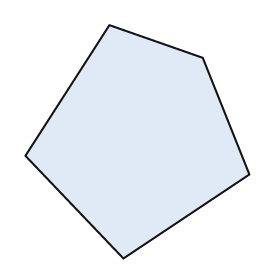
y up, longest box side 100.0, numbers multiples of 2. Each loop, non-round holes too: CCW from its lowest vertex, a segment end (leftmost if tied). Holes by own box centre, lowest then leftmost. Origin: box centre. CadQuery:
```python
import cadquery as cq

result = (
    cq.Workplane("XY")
    .moveTo(-6.0, -50.0)
    .lineTo(48.0, -14.0)
    .lineTo(28.0, 36.0)
    .lineTo(-12.0, 50.0)
    .lineTo(-48.0, -6.0)
    .close()
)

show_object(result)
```